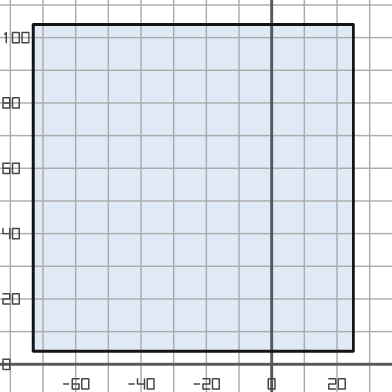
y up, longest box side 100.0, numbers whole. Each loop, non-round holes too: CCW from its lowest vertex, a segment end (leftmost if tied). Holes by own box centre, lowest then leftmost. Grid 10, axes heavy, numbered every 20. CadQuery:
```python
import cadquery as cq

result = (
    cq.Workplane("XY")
    .moveTo(-73.0, 4.0)
    .lineTo(25.0, 4.0)
    .lineTo(25.0, 104.0)
    .lineTo(-73.0, 104.0)
    .close()
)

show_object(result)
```